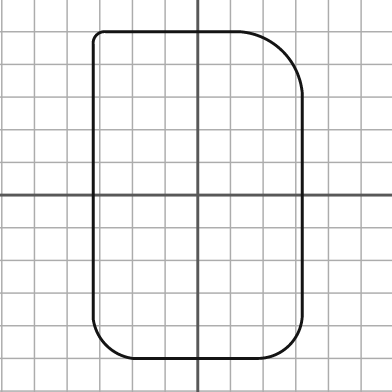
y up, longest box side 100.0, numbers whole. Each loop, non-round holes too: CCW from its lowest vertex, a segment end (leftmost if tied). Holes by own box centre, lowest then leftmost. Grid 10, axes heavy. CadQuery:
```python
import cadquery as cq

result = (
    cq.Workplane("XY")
    .moveTo(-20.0, -50.0)
    .lineTo(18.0, -50.0)
    .threePointArc((28.0, -46.0), (32.0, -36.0))
    .lineTo(32.0, 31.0)
    .threePointArc((26.0, 44.0), (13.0, 50.0))
    .lineTo(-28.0, 50.0)
    .threePointArc((-31.0, 49.0), (-32.0, 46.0))
    .lineTo(-32.0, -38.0)
    .threePointArc((-28.0, -46.0), (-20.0, -50.0))
    .close()
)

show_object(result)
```